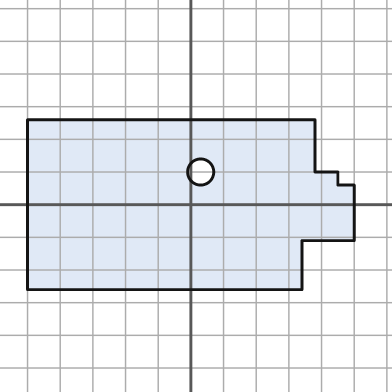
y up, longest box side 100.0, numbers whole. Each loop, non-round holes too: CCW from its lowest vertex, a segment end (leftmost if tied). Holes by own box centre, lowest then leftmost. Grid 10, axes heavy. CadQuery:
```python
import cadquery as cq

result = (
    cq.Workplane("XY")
    .moveTo(-50.0, -26.0)
    .lineTo(34.0, -26.0)
    .lineTo(34.0, -11.0)
    .lineTo(50.0, -11.0)
    .lineTo(50.0, 6.0)
    .lineTo(45.0, 6.0)
    .lineTo(45.0, 10.0)
    .lineTo(38.0, 10.0)
    .lineTo(38.0, 26.0)
    .lineTo(-50.0, 26.0)
    .close()
    .moveTo(3.0, 10.0)
    .circle(4.0)
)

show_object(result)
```